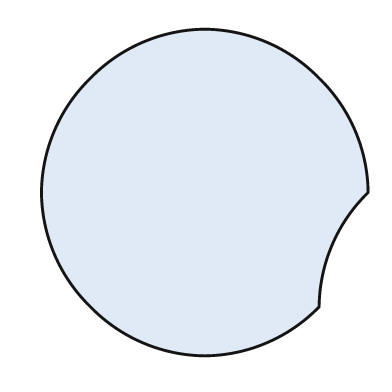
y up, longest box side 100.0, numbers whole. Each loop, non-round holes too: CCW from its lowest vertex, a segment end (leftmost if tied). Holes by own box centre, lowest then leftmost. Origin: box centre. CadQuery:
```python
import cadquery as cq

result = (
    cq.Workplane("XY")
    .moveTo(0.0, -50.0)
    .threePointArc((19.0, -46.0), (35.0, -35.0))
    .threePointArc((39.0, -16.0), (50.0, 0.0))
    .threePointArc((46.0, 19.0), (35.0, 35.0))
    .threePointArc((19.0, 46.0), (0.0, 50.0))
    .threePointArc((-19.0, 46.0), (-35.0, 35.0))
    .threePointArc((-46.0, 19.0), (-50.0, 0.0))
    .threePointArc((-46.0, -19.0), (-35.0, -35.0))
    .threePointArc((-19.0, -46.0), (0.0, -50.0))
    .close()
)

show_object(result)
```